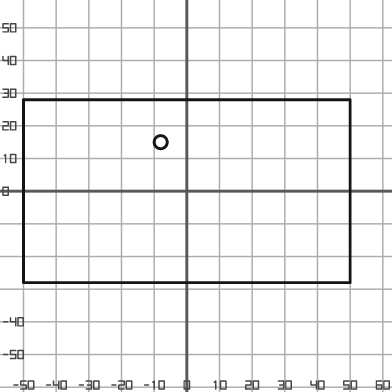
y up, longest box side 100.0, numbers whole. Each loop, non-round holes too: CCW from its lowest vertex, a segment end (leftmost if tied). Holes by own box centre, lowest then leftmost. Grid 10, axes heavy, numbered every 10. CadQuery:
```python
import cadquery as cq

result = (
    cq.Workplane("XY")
    .moveTo(-50.0, -28.0)
    .lineTo(50.0, -28.0)
    .lineTo(50.0, 28.0)
    .lineTo(-50.0, 28.0)
    .close()
    .moveTo(-8.0, 15.0)
    .circle(2.0)
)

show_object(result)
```